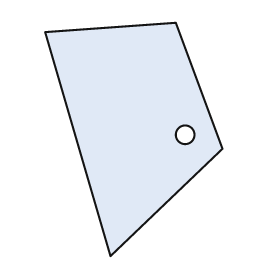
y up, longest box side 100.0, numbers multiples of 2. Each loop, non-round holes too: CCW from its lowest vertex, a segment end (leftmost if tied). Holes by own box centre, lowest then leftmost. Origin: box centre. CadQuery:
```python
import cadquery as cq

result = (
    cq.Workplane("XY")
    .moveTo(-10.0, -50.0)
    .lineTo(38.0, -4.0)
    .lineTo(18.0, 50.0)
    .lineTo(-38.0, 46.0)
    .close()
    .moveTo(22.0, 2.0)
    .circle(4.0)
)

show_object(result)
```